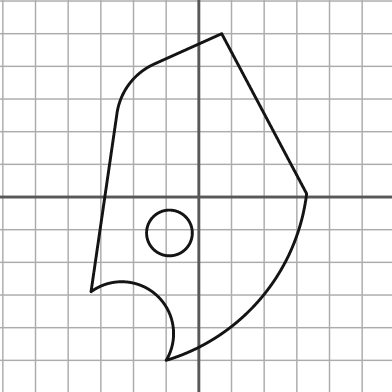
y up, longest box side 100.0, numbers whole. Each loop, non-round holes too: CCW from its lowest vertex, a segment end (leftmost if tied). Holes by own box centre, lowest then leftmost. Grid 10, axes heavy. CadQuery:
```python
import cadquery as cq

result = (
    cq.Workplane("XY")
    .moveTo(-10.0, -50.0)
    .threePointArc((19.0, -31.0), (33.0, 1.0))
    .lineTo(7.0, 50.0)
    .lineTo(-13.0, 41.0)
    .threePointArc((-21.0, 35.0), (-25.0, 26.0))
    .lineTo(-33.0, -29.0)
    .threePointArc((-13.0, -30.0), (-10.0, -50.0))
    .close()
    .moveTo(-9.0, -11.0)
    .circle(7.0)
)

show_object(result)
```